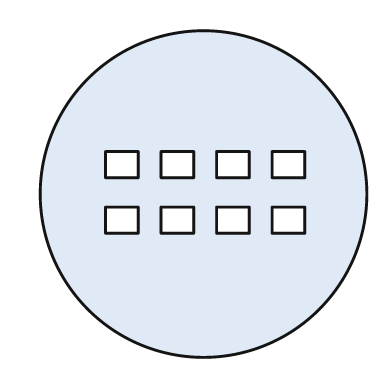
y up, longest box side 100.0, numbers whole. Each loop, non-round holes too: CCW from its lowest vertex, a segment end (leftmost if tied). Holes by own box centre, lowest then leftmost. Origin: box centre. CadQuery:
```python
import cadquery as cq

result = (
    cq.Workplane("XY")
    .moveTo(0.0, 0.0)
    .circle(50.0)
    .moveTo(-30.0, -12.0)
    .lineTo(-20.0, -12.0)
    .lineTo(-20.0, -4.0)
    .lineTo(-30.0, -4.0)
    .close()
    .moveTo(-13.0, -12.0)
    .lineTo(-3.0, -12.0)
    .lineTo(-3.0, -4.0)
    .lineTo(-13.0, -4.0)
    .close()
    .moveTo(4.0, -12.0)
    .lineTo(14.0, -12.0)
    .lineTo(14.0, -4.0)
    .lineTo(4.0, -4.0)
    .close()
    .moveTo(21.0, -12.0)
    .lineTo(31.0, -12.0)
    .lineTo(31.0, -4.0)
    .lineTo(21.0, -4.0)
    .close()
    .moveTo(-30.0, 5.0)
    .lineTo(-20.0, 5.0)
    .lineTo(-20.0, 13.0)
    .lineTo(-30.0, 13.0)
    .close()
    .moveTo(-13.0, 5.0)
    .lineTo(-3.0, 5.0)
    .lineTo(-3.0, 13.0)
    .lineTo(-13.0, 13.0)
    .close()
    .moveTo(4.0, 5.0)
    .lineTo(14.0, 5.0)
    .lineTo(14.0, 13.0)
    .lineTo(4.0, 13.0)
    .close()
    .moveTo(21.0, 5.0)
    .lineTo(31.0, 5.0)
    .lineTo(31.0, 13.0)
    .lineTo(21.0, 13.0)
    .close()
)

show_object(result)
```